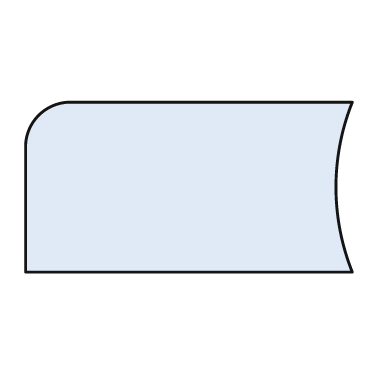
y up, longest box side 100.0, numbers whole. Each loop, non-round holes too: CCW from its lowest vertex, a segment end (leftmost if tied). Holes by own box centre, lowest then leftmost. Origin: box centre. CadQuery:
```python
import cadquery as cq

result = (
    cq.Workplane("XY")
    .moveTo(-50.0, -26.0)
    .lineTo(50.0, -26.0)
    .threePointArc((45.0, 0.0), (50.0, 26.0))
    .lineTo(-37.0, 26.0)
    .threePointArc((-46.0, 22.0), (-50.0, 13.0))
    .close()
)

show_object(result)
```